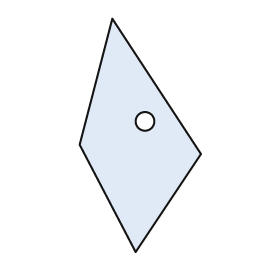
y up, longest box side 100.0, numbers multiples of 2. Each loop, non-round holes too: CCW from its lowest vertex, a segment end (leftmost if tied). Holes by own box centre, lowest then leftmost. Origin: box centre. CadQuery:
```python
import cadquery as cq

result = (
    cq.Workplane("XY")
    .moveTo(-2.0, -50.0)
    .lineTo(26.0, -8.0)
    .lineTo(-12.0, 50.0)
    .lineTo(-26.0, -4.0)
    .close()
    .moveTo(2.0, 6.0)
    .circle(4.0)
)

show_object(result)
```